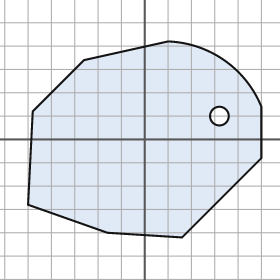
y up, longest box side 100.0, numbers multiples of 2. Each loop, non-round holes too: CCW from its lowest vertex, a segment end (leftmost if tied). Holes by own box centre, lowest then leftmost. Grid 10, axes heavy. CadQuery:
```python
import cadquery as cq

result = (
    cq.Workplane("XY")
    .moveTo(16.0, -42.0)
    .lineTo(50.0, -8.0)
    .lineTo(50.0, 14.0)
    .threePointArc((34.0, 34.0), (10.0, 42.0))
    .lineTo(-26.0, 34.0)
    .lineTo(-48.0, 12.0)
    .lineTo(-50.0, -28.0)
    .lineTo(-16.0, -40.0)
    .close()
    .moveTo(32.0, 10.0)
    .circle(4.0)
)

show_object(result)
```